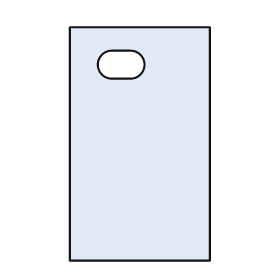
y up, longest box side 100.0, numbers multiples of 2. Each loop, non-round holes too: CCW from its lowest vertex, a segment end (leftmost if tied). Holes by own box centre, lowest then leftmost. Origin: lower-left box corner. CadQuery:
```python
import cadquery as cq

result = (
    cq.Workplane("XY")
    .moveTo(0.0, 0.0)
    .lineTo(60.0, 0.0)
    .lineTo(60.0, 100.0)
    .lineTo(0.0, 100.0)
    .close()
    .moveTo(18.0, 78.0)
    .lineTo(26.0, 78.0)
    .threePointArc((32.0, 84.0), (26.0, 90.0))
    .lineTo(18.0, 90.0)
    .threePointArc((12.0, 84.0), (18.0, 78.0))
    .close()
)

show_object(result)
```